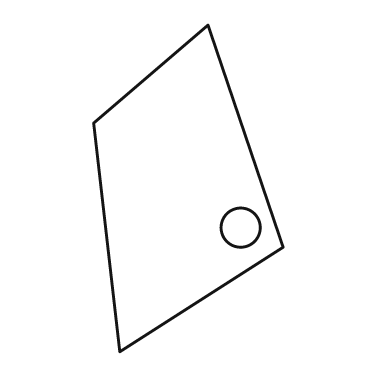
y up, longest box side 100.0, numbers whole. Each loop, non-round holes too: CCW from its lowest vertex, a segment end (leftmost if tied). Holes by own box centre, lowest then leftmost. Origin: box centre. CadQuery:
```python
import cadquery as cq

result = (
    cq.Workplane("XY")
    .moveTo(-21.0, -50.0)
    .lineTo(29.0, -18.0)
    .lineTo(6.0, 50.0)
    .lineTo(-29.0, 20.0)
    .close()
    .moveTo(16.0, -12.0)
    .circle(6.0)
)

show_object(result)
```